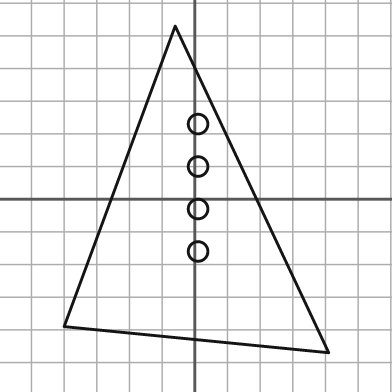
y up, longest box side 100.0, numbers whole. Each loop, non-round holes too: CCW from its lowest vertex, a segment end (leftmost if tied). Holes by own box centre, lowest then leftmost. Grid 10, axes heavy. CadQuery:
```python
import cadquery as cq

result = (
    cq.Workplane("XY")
    .moveTo(41.0, -47.0)
    .lineTo(-6.0, 53.0)
    .lineTo(-40.0, -39.0)
    .close()
    .moveTo(1.0, -16.0)
    .circle(3.0)
    .moveTo(1.0, -3.0)
    .circle(3.0)
    .moveTo(1.0, 10.0)
    .circle(3.0)
    .moveTo(1.0, 23.0)
    .circle(3.0)
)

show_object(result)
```